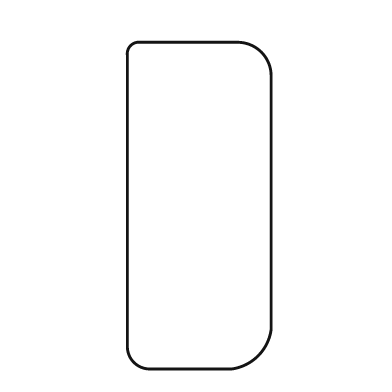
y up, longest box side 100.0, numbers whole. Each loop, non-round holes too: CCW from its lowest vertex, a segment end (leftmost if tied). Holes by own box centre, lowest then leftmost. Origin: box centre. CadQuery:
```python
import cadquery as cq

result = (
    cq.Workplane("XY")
    .moveTo(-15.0, -50.0)
    .lineTo(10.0, -50.0)
    .threePointArc((18.0, -46.0), (22.0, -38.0))
    .lineTo(22.0, 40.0)
    .threePointArc((19.0, 47.0), (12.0, 50.0))
    .lineTo(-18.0, 50.0)
    .threePointArc((-21.0, 49.0), (-22.0, 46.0))
    .lineTo(-22.0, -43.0)
    .threePointArc((-20.0, -48.0), (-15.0, -50.0))
    .close()
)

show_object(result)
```